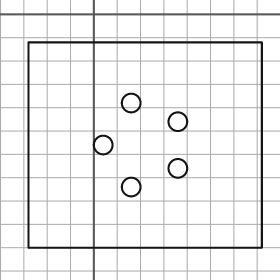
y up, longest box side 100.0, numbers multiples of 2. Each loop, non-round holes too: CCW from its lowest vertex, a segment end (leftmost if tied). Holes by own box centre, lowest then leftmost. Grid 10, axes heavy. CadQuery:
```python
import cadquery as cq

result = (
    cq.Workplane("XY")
    .moveTo(-28.0, -100.0)
    .lineTo(72.0, -100.0)
    .lineTo(72.0, -12.0)
    .lineTo(-28.0, -12.0)
    .close()
    .moveTo(16.0, -74.0)
    .circle(4.0)
    .moveTo(36.0, -66.0)
    .circle(4.0)
    .moveTo(4.0, -56.0)
    .circle(4.0)
    .moveTo(36.0, -46.0)
    .circle(4.0)
    .moveTo(16.0, -38.0)
    .circle(4.0)
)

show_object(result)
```